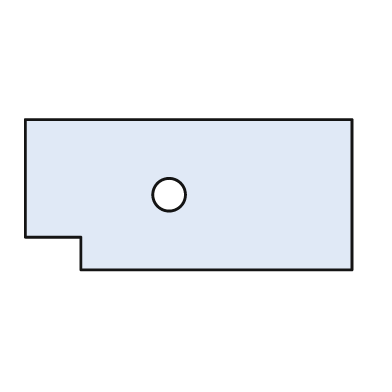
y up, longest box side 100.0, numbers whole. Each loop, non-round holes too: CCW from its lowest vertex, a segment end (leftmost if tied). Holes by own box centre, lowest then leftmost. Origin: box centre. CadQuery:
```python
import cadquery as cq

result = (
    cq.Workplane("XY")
    .moveTo(-33.0, -23.0)
    .lineTo(50.0, -23.0)
    .lineTo(50.0, 23.0)
    .lineTo(-50.0, 23.0)
    .lineTo(-50.0, -13.0)
    .lineTo(-33.0, -13.0)
    .close()
    .moveTo(-6.0, 0.0)
    .circle(5.0)
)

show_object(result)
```